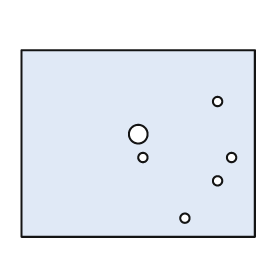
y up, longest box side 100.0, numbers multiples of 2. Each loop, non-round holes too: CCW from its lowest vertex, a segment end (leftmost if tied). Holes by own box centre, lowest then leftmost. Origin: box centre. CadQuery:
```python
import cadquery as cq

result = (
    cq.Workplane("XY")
    .moveTo(-50.0, -40.0)
    .lineTo(50.0, -40.0)
    .lineTo(50.0, 40.0)
    .lineTo(-50.0, 40.0)
    .close()
    .moveTo(20.0, -32.0)
    .circle(2.0)
    .moveTo(34.0, -16.0)
    .circle(2.0)
    .moveTo(2.0, -6.0)
    .circle(2.0)
    .moveTo(40.0, -6.0)
    .circle(2.0)
    .moveTo(0.0, 4.0)
    .circle(4.0)
    .moveTo(34.0, 18.0)
    .circle(2.0)
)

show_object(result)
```